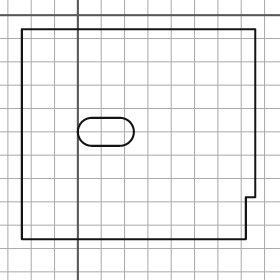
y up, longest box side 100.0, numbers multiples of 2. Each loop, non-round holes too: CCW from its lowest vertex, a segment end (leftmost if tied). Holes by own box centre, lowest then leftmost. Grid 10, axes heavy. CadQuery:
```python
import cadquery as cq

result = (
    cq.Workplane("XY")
    .moveTo(-24.0, -96.0)
    .lineTo(72.0, -96.0)
    .lineTo(72.0, -78.0)
    .lineTo(76.0, -78.0)
    .lineTo(76.0, -6.0)
    .lineTo(-24.0, -6.0)
    .close()
    .moveTo(6.0, -56.0)
    .lineTo(18.0, -56.0)
    .threePointArc((24.0, -50.0), (18.0, -44.0))
    .lineTo(6.0, -44.0)
    .threePointArc((0.0, -50.0), (6.0, -56.0))
    .close()
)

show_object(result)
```